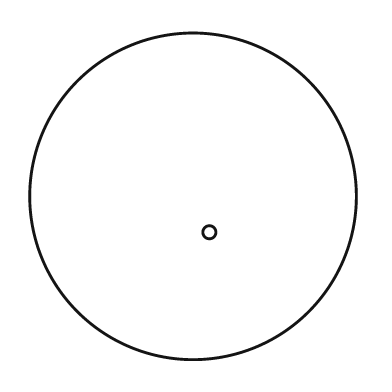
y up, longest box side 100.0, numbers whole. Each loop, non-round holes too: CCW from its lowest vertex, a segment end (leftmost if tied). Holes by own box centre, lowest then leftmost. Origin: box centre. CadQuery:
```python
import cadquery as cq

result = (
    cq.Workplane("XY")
    .moveTo(0.0, 0.0)
    .circle(50.0)
    .moveTo(5.0, -11.0)
    .circle(2.0)
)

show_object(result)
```